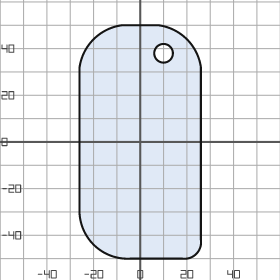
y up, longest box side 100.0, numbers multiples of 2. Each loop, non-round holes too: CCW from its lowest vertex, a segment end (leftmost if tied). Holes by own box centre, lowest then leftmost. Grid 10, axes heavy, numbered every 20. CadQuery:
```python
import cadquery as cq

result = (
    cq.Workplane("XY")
    .moveTo(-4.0, -50.0)
    .lineTo(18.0, -50.0)
    .threePointArc((24.0, -48.0), (26.0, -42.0))
    .lineTo(26.0, 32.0)
    .threePointArc((20.0, 44.0), (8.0, 50.0))
    .lineTo(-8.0, 50.0)
    .threePointArc((-20.0, 44.0), (-26.0, 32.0))
    .lineTo(-26.0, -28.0)
    .threePointArc((-20.0, -44.0), (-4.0, -50.0))
    .close()
    .moveTo(10.0, 38.0)
    .circle(4.0)
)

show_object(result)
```